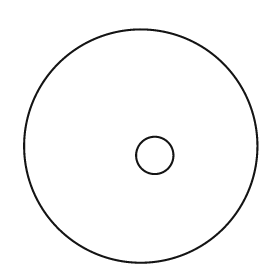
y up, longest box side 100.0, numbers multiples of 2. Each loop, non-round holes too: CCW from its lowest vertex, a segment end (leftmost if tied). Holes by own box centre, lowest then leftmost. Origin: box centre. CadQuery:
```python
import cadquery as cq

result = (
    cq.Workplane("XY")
    .moveTo(0.0, 0.0)
    .circle(50.0)
    .moveTo(6.0, -4.0)
    .circle(8.0)
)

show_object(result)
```